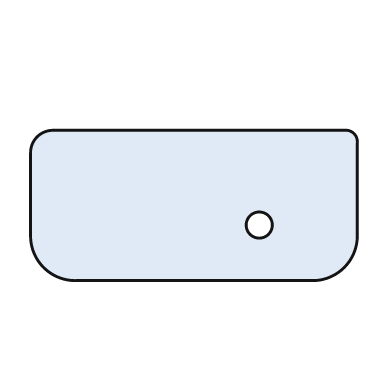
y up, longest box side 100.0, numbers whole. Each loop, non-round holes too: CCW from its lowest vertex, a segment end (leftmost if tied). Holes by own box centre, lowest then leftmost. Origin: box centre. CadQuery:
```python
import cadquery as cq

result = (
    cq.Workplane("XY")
    .moveTo(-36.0, -23.0)
    .lineTo(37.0, -23.0)
    .threePointArc((46.0, -19.0), (50.0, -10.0))
    .lineTo(50.0, 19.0)
    .threePointArc((49.0, 22.0), (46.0, 23.0))
    .lineTo(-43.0, 23.0)
    .threePointArc((-48.0, 21.0), (-50.0, 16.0))
    .lineTo(-50.0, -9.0)
    .threePointArc((-46.0, -19.0), (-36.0, -23.0))
    .close()
    .moveTo(20.0, -6.0)
    .circle(4.0)
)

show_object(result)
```